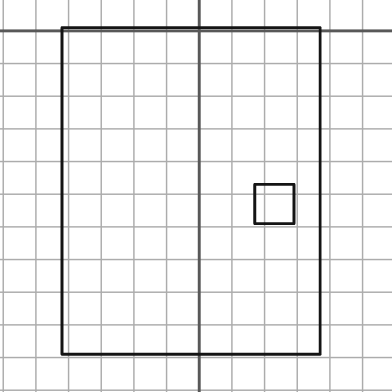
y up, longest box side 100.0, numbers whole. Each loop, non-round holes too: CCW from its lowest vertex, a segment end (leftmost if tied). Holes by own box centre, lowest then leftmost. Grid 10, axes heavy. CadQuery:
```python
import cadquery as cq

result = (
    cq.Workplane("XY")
    .moveTo(-42.0, -99.0)
    .lineTo(37.0, -99.0)
    .lineTo(37.0, 1.0)
    .lineTo(-42.0, 1.0)
    .close()
    .moveTo(17.0, -59.0)
    .lineTo(29.0, -59.0)
    .lineTo(29.0, -47.0)
    .lineTo(17.0, -47.0)
    .close()
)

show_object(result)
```